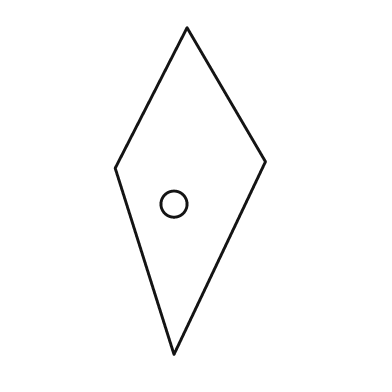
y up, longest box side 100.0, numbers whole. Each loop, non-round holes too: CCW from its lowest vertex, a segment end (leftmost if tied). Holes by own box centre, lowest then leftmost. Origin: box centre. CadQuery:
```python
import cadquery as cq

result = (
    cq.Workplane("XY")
    .moveTo(-5.0, -50.0)
    .lineTo(23.0, 9.0)
    .lineTo(-1.0, 50.0)
    .lineTo(-23.0, 7.0)
    .close()
    .moveTo(-5.0, -4.0)
    .circle(4.0)
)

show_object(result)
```